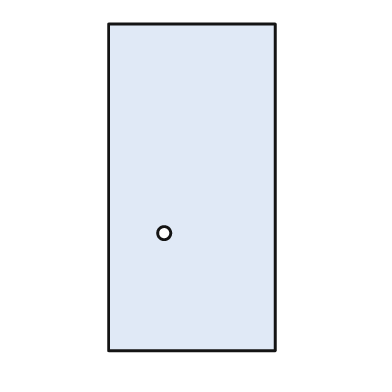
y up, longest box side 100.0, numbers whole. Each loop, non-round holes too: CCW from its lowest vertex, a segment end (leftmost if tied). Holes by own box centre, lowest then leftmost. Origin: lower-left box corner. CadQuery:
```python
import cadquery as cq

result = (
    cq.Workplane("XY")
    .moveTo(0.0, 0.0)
    .lineTo(51.0, 0.0)
    .lineTo(51.0, 100.0)
    .lineTo(0.0, 100.0)
    .close()
    .moveTo(17.0, 36.0)
    .circle(2.0)
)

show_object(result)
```